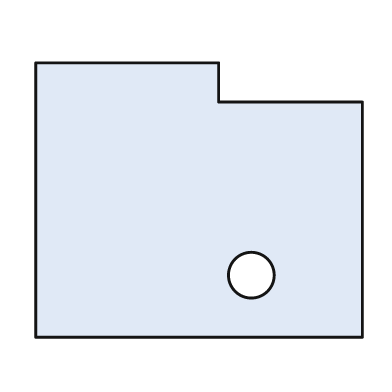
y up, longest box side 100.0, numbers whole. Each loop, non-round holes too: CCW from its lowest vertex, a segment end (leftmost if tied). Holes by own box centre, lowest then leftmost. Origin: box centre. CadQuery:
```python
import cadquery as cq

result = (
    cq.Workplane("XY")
    .moveTo(-50.0, -42.0)
    .lineTo(50.0, -42.0)
    .lineTo(50.0, 30.0)
    .lineTo(6.0, 30.0)
    .lineTo(6.0, 42.0)
    .lineTo(-50.0, 42.0)
    .close()
    .moveTo(16.0, -23.0)
    .circle(7.0)
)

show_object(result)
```